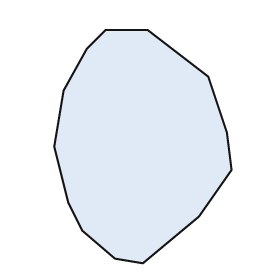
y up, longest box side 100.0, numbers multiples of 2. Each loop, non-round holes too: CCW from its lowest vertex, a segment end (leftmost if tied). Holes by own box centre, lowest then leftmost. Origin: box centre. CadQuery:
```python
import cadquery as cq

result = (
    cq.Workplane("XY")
    .moveTo(0.0, -50.0)
    .lineTo(24.0, -30.0)
    .lineTo(38.0, -10.0)
    .lineTo(36.0, 6.0)
    .lineTo(28.0, 30.0)
    .lineTo(2.0, 50.0)
    .lineTo(-16.0, 50.0)
    .lineTo(-24.0, 42.0)
    .lineTo(-34.0, 24.0)
    .lineTo(-38.0, 0.0)
    .lineTo(-32.0, -24.0)
    .lineTo(-26.0, -36.0)
    .lineTo(-12.0, -48.0)
    .close()
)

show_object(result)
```